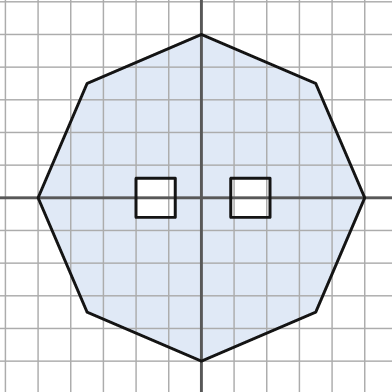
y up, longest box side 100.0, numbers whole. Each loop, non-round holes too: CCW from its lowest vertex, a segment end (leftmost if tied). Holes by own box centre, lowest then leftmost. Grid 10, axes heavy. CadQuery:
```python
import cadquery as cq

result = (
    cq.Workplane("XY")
    .moveTo(0.0, -50.0)
    .lineTo(35.0, -35.0)
    .lineTo(50.0, 0.0)
    .lineTo(35.0, 35.0)
    .lineTo(0.0, 50.0)
    .lineTo(-35.0, 35.0)
    .lineTo(-50.0, 0.0)
    .lineTo(-35.0, -35.0)
    .close()
    .moveTo(-20.0, -6.0)
    .lineTo(-8.0, -6.0)
    .lineTo(-8.0, 6.0)
    .lineTo(-20.0, 6.0)
    .close()
    .moveTo(9.0, -6.0)
    .lineTo(21.0, -6.0)
    .lineTo(21.0, 6.0)
    .lineTo(9.0, 6.0)
    .close()
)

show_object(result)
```